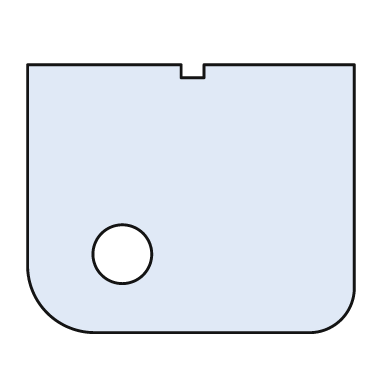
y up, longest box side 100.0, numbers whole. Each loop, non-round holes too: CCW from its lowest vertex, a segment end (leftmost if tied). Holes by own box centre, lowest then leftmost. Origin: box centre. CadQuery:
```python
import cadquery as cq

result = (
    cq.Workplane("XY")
    .moveTo(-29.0, -41.0)
    .lineTo(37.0, -41.0)
    .threePointArc((46.0, -37.0), (50.0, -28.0))
    .lineTo(50.0, 41.0)
    .lineTo(4.0, 41.0)
    .lineTo(4.0, 37.0)
    .lineTo(-3.0, 37.0)
    .lineTo(-3.0, 41.0)
    .lineTo(-50.0, 41.0)
    .lineTo(-50.0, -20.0)
    .threePointArc((-44.0, -35.0), (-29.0, -41.0))
    .close()
    .moveTo(-21.0, -17.0)
    .circle(9.0)
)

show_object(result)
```